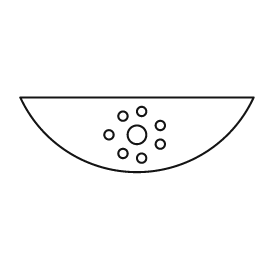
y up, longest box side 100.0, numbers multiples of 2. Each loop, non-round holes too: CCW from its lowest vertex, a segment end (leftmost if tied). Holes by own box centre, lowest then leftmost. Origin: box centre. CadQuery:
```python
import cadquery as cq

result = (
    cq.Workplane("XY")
    .moveTo(-50.0, 16.0)
    .threePointArc((0.0, -16.0), (50.0, 16.0))
    .close()
    .moveTo(2.0, -10.0)
    .circle(2.0)
    .moveTo(-6.0, -8.0)
    .circle(2.0)
    .moveTo(10.0, -4.0)
    .circle(2.0)
    .moveTo(-12.0, 0.0)
    .circle(2.0)
    .moveTo(0.0, 0.0)
    .circle(4.0)
    .moveTo(10.0, 4.0)
    .circle(2.0)
    .moveTo(-6.0, 8.0)
    .circle(2.0)
    .moveTo(2.0, 10.0)
    .circle(2.0)
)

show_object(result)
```